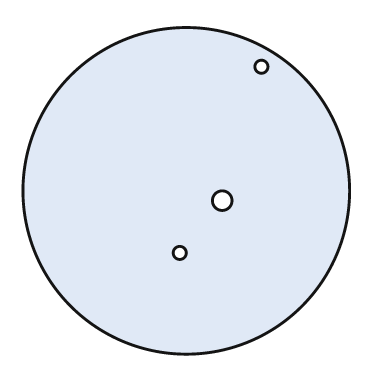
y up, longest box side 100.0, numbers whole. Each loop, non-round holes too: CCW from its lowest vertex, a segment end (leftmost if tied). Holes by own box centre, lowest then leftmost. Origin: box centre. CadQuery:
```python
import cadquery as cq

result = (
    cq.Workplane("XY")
    .moveTo(0.0, 0.0)
    .circle(50.0)
    .moveTo(-2.0, -19.0)
    .circle(2.0)
    .moveTo(11.0, -3.0)
    .circle(3.0)
    .moveTo(23.0, 38.0)
    .circle(2.0)
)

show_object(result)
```